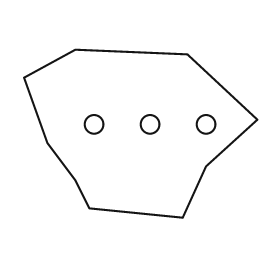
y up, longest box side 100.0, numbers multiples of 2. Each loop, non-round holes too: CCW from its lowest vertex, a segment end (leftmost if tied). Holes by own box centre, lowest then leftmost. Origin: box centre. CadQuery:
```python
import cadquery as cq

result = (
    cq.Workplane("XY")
    .moveTo(18.0, -36.0)
    .lineTo(28.0, -14.0)
    .lineTo(50.0, 6.0)
    .lineTo(20.0, 34.0)
    .lineTo(-28.0, 36.0)
    .lineTo(-50.0, 24.0)
    .lineTo(-40.0, -4.0)
    .lineTo(-28.0, -20.0)
    .lineTo(-22.0, -32.0)
    .close()
    .moveTo(-20.0, 4.0)
    .circle(4.0)
    .moveTo(4.0, 4.0)
    .circle(4.0)
    .moveTo(28.0, 4.0)
    .circle(4.0)
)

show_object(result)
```